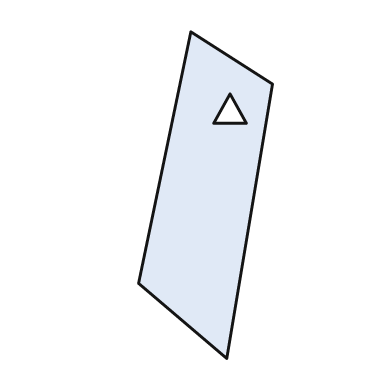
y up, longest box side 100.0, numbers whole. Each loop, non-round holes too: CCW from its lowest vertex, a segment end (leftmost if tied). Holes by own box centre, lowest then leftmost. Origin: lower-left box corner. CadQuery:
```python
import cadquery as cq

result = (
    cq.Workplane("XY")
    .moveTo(27.0, 0.0)
    .lineTo(41.0, 84.0)
    .lineTo(16.0, 100.0)
    .lineTo(0.0, 23.0)
    .close()
    .moveTo(23.0, 72.0)
    .lineTo(33.0, 72.0)
    .lineTo(28.0, 81.0)
    .close()
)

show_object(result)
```